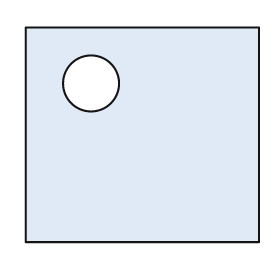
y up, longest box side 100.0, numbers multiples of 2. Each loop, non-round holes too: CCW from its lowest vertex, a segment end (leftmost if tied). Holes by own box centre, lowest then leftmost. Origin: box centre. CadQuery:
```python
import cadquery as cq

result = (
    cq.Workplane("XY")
    .moveTo(-50.0, -46.0)
    .lineTo(50.0, -46.0)
    .lineTo(50.0, 46.0)
    .lineTo(-50.0, 46.0)
    .close()
    .moveTo(-22.0, 22.0)
    .circle(12.0)
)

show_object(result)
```